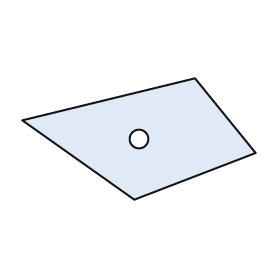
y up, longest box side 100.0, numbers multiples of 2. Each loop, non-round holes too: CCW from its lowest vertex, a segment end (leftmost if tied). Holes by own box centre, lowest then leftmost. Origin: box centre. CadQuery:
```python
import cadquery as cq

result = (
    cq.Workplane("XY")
    .moveTo(-2.0, -26.0)
    .lineTo(50.0, -6.0)
    .lineTo(24.0, 26.0)
    .lineTo(-50.0, 8.0)
    .close()
    .moveTo(0.0, 0.0)
    .circle(4.0)
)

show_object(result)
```